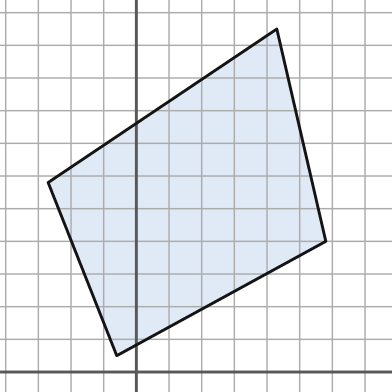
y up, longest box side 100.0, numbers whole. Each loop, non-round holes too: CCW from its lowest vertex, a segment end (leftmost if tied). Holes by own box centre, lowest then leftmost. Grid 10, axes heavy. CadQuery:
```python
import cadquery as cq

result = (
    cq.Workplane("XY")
    .moveTo(-6.0, 5.0)
    .lineTo(58.0, 40.0)
    .lineTo(43.0, 105.0)
    .lineTo(-27.0, 58.0)
    .close()
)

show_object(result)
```